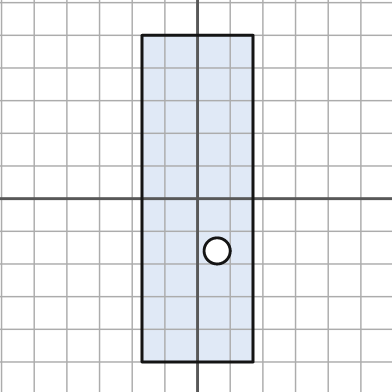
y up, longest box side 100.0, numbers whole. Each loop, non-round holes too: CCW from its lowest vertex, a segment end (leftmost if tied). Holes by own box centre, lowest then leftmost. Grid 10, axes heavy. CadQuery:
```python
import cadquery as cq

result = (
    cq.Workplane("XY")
    .moveTo(-17.0, -50.0)
    .lineTo(17.0, -50.0)
    .lineTo(17.0, 50.0)
    .lineTo(-17.0, 50.0)
    .close()
    .moveTo(6.0, -16.0)
    .circle(4.0)
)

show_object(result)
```